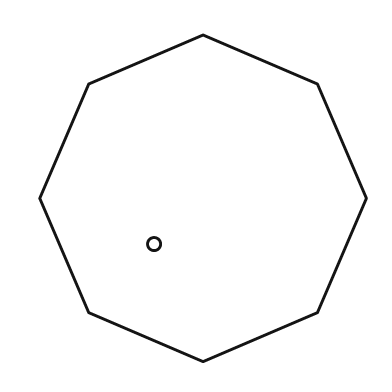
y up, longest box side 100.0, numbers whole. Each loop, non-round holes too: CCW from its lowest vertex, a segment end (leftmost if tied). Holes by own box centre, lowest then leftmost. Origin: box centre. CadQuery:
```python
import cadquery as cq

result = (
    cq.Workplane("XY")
    .moveTo(0.0, -50.0)
    .lineTo(35.0, -35.0)
    .lineTo(50.0, 0.0)
    .lineTo(35.0, 35.0)
    .lineTo(0.0, 50.0)
    .lineTo(-35.0, 35.0)
    .lineTo(-50.0, 0.0)
    .lineTo(-35.0, -35.0)
    .close()
    .moveTo(-15.0, -14.0)
    .circle(2.0)
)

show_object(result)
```